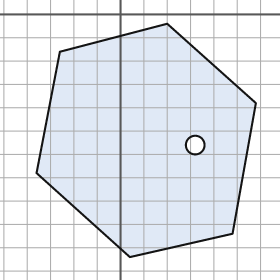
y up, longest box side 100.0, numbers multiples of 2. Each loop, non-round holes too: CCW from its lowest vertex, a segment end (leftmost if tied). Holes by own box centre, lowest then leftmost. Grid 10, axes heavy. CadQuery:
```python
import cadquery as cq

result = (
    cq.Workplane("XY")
    .moveTo(4.0, -104.0)
    .lineTo(48.0, -94.0)
    .lineTo(58.0, -38.0)
    .lineTo(20.0, -4.0)
    .lineTo(-26.0, -16.0)
    .lineTo(-36.0, -68.0)
    .close()
    .moveTo(32.0, -56.0)
    .circle(4.0)
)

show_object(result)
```